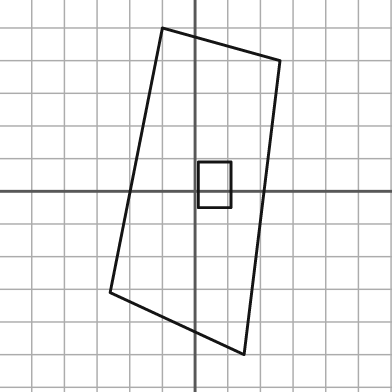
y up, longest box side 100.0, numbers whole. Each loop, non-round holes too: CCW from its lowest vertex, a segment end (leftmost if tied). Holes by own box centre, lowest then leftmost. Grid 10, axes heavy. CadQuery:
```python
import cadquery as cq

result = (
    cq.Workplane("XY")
    .moveTo(15.0, -50.0)
    .lineTo(26.0, 40.0)
    .lineTo(-10.0, 50.0)
    .lineTo(-26.0, -31.0)
    .close()
    .moveTo(1.0, -5.0)
    .lineTo(11.0, -5.0)
    .lineTo(11.0, 9.0)
    .lineTo(1.0, 9.0)
    .close()
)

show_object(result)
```